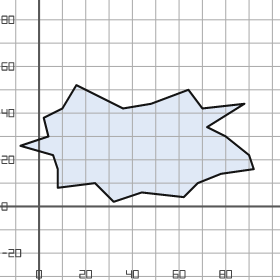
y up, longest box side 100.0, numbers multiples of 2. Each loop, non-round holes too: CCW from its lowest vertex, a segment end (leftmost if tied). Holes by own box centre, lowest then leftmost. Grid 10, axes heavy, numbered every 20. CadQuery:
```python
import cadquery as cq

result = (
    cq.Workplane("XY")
    .moveTo(32.0, 2.0)
    .lineTo(44.0, 6.0)
    .lineTo(62.0, 4.0)
    .lineTo(68.0, 10.0)
    .lineTo(78.0, 14.0)
    .lineTo(92.0, 16.0)
    .lineTo(90.0, 22.0)
    .lineTo(80.0, 30.0)
    .lineTo(72.0, 34.0)
    .lineTo(88.0, 44.0)
    .lineTo(70.0, 42.0)
    .lineTo(64.0, 50.0)
    .lineTo(48.0, 44.0)
    .lineTo(36.0, 42.0)
    .lineTo(16.0, 52.0)
    .lineTo(10.0, 42.0)
    .lineTo(2.0, 38.0)
    .lineTo(4.0, 30.0)
    .lineTo(-8.0, 26.0)
    .lineTo(6.0, 22.0)
    .lineTo(8.0, 16.0)
    .lineTo(8.0, 8.0)
    .lineTo(24.0, 10.0)
    .close()
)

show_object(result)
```